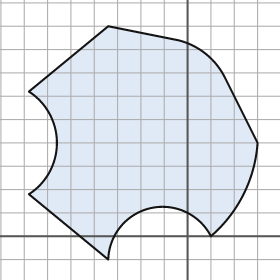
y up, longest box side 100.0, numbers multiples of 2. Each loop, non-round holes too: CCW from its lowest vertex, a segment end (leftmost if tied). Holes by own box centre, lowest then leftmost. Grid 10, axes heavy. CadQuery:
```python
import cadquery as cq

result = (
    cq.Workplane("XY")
    .moveTo(-34.0, -10.0)
    .threePointArc((-16.0, 12.0), (10.0, 0.0))
    .threePointArc((24.0, 18.0), (30.0, 40.0))
    .lineTo(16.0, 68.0)
    .threePointArc((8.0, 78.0), (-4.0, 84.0))
    .lineTo(-34.0, 90.0)
    .lineTo(-68.0, 62.0)
    .threePointArc((-56.0, 40.0), (-68.0, 18.0))
    .close()
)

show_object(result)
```